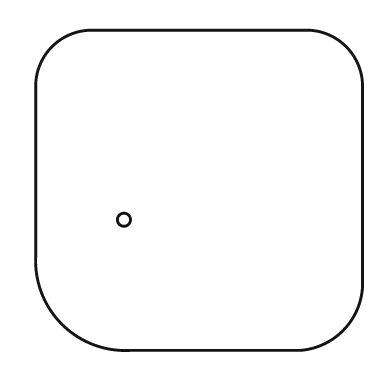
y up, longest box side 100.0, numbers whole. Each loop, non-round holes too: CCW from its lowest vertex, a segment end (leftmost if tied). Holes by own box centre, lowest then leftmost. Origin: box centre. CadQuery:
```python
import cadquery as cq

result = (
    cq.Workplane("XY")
    .moveTo(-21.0, -49.0)
    .lineTo(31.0, -49.0)
    .threePointArc((44.0, -43.0), (50.0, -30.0))
    .lineTo(50.0, 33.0)
    .threePointArc((45.0, 44.0), (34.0, 49.0))
    .lineTo(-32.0, 49.0)
    .threePointArc((-45.0, 44.0), (-50.0, 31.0))
    .lineTo(-50.0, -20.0)
    .threePointArc((-42.0, -41.0), (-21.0, -49.0))
    .close()
    .moveTo(-23.0, -9.0)
    .circle(2.0)
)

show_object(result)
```